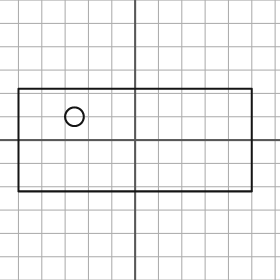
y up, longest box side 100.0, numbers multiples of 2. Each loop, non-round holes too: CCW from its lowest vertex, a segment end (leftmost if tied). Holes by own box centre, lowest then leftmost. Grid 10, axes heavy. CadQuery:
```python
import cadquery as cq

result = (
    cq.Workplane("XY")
    .moveTo(-50.0, -22.0)
    .lineTo(50.0, -22.0)
    .lineTo(50.0, 22.0)
    .lineTo(-50.0, 22.0)
    .close()
    .moveTo(-26.0, 10.0)
    .circle(4.0)
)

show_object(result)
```